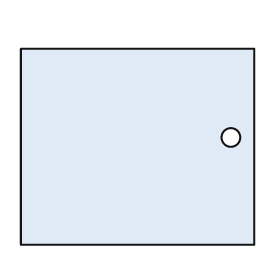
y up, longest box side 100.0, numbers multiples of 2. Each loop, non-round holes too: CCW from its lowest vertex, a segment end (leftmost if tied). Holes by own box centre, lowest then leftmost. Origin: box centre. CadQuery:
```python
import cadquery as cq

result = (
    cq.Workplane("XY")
    .moveTo(-50.0, -42.0)
    .lineTo(50.0, -42.0)
    .lineTo(50.0, 42.0)
    .lineTo(-50.0, 42.0)
    .close()
    .moveTo(40.0, 4.0)
    .circle(4.0)
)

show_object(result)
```